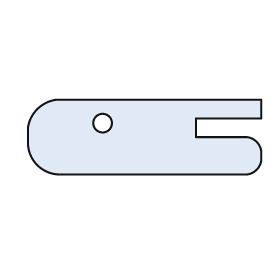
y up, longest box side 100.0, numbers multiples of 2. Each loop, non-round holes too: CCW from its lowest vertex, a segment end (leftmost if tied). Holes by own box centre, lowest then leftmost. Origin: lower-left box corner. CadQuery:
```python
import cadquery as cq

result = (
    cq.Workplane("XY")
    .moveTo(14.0, 0.0)
    .lineTo(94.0, 0.0)
    .threePointArc((98.0, 2.0), (100.0, 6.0))
    .lineTo(100.0, 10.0)
    .threePointArc((98.0, 14.0), (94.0, 16.0))
    .lineTo(72.0, 16.0)
    .lineTo(72.0, 24.0)
    .lineTo(100.0, 24.0)
    .lineTo(100.0, 32.0)
    .lineTo(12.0, 32.0)
    .threePointArc((4.0, 28.0), (0.0, 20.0))
    .lineTo(0.0, 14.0)
    .threePointArc((4.0, 4.0), (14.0, 0.0))
    .close()
    .moveTo(32.0, 22.0)
    .circle(4.0)
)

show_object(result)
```